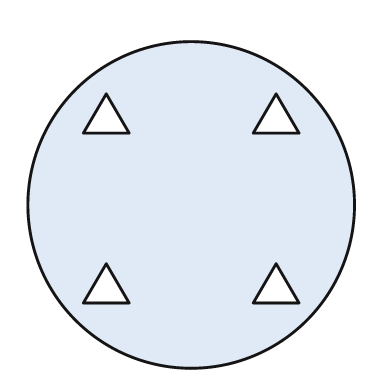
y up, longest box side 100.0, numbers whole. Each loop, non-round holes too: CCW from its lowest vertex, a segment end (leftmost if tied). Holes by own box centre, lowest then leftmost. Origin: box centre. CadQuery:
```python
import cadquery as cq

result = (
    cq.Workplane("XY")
    .moveTo(0.0, 0.0)
    .circle(50.0)
    .moveTo(-33.0, -30.0)
    .lineTo(-19.0, -30.0)
    .lineTo(-26.0, -18.0)
    .close()
    .moveTo(19.0, -30.0)
    .lineTo(33.0, -30.0)
    .lineTo(26.0, -18.0)
    .close()
    .moveTo(-33.0, 22.0)
    .lineTo(-19.0, 22.0)
    .lineTo(-26.0, 34.0)
    .close()
    .moveTo(19.0, 22.0)
    .lineTo(33.0, 22.0)
    .lineTo(26.0, 34.0)
    .close()
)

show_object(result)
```